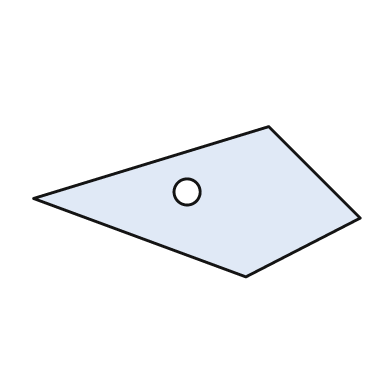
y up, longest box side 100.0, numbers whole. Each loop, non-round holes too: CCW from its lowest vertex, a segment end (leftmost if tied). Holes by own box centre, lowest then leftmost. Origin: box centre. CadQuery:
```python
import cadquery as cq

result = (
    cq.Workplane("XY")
    .moveTo(15.0, -23.0)
    .lineTo(50.0, -5.0)
    .lineTo(22.0, 23.0)
    .lineTo(-50.0, 1.0)
    .close()
    .moveTo(-3.0, 3.0)
    .circle(4.0)
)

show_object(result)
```